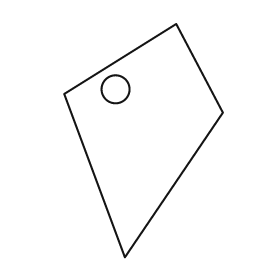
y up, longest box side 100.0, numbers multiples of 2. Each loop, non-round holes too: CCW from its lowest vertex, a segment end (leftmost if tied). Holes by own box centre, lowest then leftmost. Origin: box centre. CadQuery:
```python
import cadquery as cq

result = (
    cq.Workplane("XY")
    .moveTo(-8.0, -50.0)
    .lineTo(34.0, 12.0)
    .lineTo(14.0, 50.0)
    .lineTo(-34.0, 20.0)
    .close()
    .moveTo(-12.0, 22.0)
    .circle(6.0)
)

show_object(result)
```